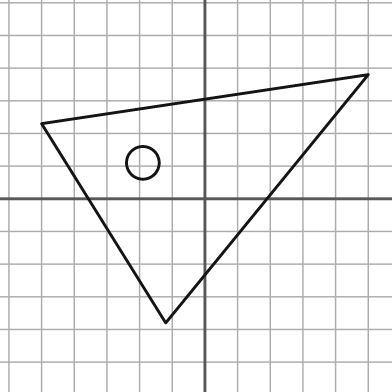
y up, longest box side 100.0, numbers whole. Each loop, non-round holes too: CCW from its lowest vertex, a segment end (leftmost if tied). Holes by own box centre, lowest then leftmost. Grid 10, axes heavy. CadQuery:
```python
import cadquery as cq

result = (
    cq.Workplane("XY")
    .moveTo(-12.0, -38.0)
    .lineTo(50.0, 38.0)
    .lineTo(-50.0, 23.0)
    .close()
    .moveTo(-19.0, 11.0)
    .circle(5.0)
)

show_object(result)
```